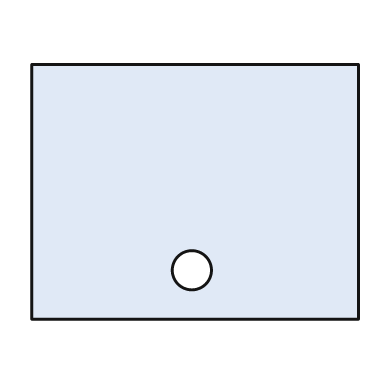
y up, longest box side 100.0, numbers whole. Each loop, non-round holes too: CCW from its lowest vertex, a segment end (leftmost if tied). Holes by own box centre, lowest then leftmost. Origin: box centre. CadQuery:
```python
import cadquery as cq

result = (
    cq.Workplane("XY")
    .moveTo(-50.0, -39.0)
    .lineTo(50.0, -39.0)
    .lineTo(50.0, 39.0)
    .lineTo(-50.0, 39.0)
    .close()
    .moveTo(-1.0, -24.0)
    .circle(6.0)
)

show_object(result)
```